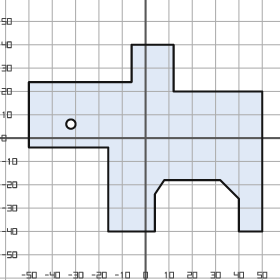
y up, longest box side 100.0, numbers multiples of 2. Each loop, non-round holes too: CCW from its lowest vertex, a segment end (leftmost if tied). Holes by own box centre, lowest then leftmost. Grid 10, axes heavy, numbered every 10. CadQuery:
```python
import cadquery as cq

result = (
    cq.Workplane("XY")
    .moveTo(-16.0, -40.0)
    .lineTo(4.0, -40.0)
    .lineTo(4.0, -24.0)
    .lineTo(8.0, -18.0)
    .lineTo(32.0, -18.0)
    .lineTo(40.0, -26.0)
    .lineTo(40.0, -40.0)
    .lineTo(50.0, -40.0)
    .lineTo(50.0, 20.0)
    .lineTo(12.0, 20.0)
    .lineTo(12.0, 40.0)
    .lineTo(-6.0, 40.0)
    .lineTo(-6.0, 24.0)
    .lineTo(-50.0, 24.0)
    .lineTo(-50.0, -4.0)
    .lineTo(-16.0, -4.0)
    .close()
    .moveTo(-32.0, 6.0)
    .circle(2.0)
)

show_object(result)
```